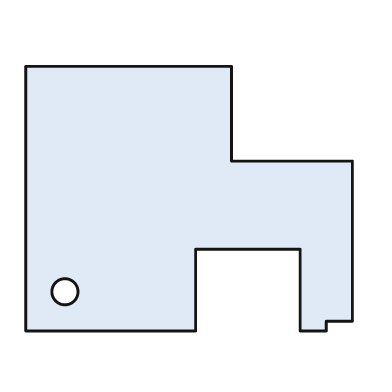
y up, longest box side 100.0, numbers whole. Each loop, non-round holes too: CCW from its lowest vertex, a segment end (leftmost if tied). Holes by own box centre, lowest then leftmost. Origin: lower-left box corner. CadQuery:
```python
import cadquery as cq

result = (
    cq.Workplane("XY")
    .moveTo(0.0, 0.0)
    .lineTo(52.0, 0.0)
    .lineTo(52.0, 25.0)
    .lineTo(84.0, 25.0)
    .lineTo(84.0, 0.0)
    .lineTo(92.0, 0.0)
    .lineTo(92.0, 3.0)
    .lineTo(100.0, 3.0)
    .lineTo(100.0, 52.0)
    .lineTo(63.0, 52.0)
    .lineTo(63.0, 81.0)
    .lineTo(0.0, 81.0)
    .close()
    .moveTo(12.0, 12.0)
    .circle(4.0)
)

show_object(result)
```